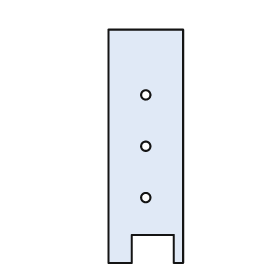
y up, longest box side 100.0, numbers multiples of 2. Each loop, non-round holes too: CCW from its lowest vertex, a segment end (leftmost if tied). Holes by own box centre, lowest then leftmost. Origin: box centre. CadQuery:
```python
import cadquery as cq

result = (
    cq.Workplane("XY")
    .moveTo(-16.0, -50.0)
    .lineTo(-6.0, -50.0)
    .lineTo(-6.0, -38.0)
    .lineTo(12.0, -38.0)
    .lineTo(12.0, -50.0)
    .lineTo(16.0, -50.0)
    .lineTo(16.0, 50.0)
    .lineTo(-16.0, 50.0)
    .close()
    .moveTo(0.0, -22.0)
    .circle(2.0)
    .moveTo(0.0, 0.0)
    .circle(2.0)
    .moveTo(0.0, 22.0)
    .circle(2.0)
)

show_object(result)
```